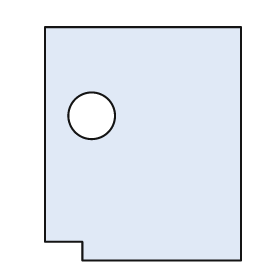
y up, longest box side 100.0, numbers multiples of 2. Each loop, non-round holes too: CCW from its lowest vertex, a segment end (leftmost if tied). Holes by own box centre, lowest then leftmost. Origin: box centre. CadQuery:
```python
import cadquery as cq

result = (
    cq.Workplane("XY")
    .moveTo(-26.0, -50.0)
    .lineTo(42.0, -50.0)
    .lineTo(42.0, 50.0)
    .lineTo(-42.0, 50.0)
    .lineTo(-42.0, -42.0)
    .lineTo(-26.0, -42.0)
    .close()
    .moveTo(-22.0, 12.0)
    .circle(10.0)
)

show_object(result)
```